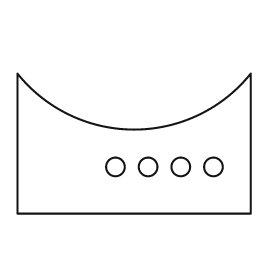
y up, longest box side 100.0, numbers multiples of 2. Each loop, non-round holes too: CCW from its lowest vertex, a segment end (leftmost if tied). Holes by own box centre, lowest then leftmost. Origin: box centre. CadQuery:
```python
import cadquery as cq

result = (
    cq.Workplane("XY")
    .moveTo(-50.0, -30.0)
    .lineTo(50.0, -30.0)
    .lineTo(50.0, 30.0)
    .threePointArc((0.0, 6.0), (-50.0, 30.0))
    .close()
    .moveTo(-8.0, -10.0)
    .circle(4.0)
    .moveTo(6.0, -10.0)
    .circle(4.0)
    .moveTo(20.0, -10.0)
    .circle(4.0)
    .moveTo(34.0, -10.0)
    .circle(4.0)
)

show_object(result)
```